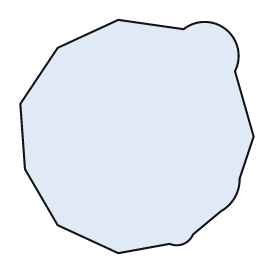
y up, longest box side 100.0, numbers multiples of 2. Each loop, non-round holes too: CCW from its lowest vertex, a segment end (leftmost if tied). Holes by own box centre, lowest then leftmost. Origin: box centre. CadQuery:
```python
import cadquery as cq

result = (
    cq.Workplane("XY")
    .moveTo(-8.0, -50.0)
    .lineTo(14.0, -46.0)
    .threePointArc((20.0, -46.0), (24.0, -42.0))
    .lineTo(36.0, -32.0)
    .threePointArc((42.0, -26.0), (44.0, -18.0))
    .lineTo(50.0, 0.0)
    .lineTo(42.0, 28.0)
    .threePointArc((38.0, 46.0), (20.0, 46.0))
    .lineTo(-8.0, 50.0)
    .lineTo(-34.0, 38.0)
    .lineTo(-50.0, 14.0)
    .lineTo(-48.0, -14.0)
    .lineTo(-34.0, -38.0)
    .close()
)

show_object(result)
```